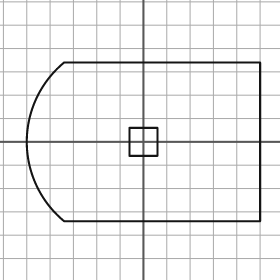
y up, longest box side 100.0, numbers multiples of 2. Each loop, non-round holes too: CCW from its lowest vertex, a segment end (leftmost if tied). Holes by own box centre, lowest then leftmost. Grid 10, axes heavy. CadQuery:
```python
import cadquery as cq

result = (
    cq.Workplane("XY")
    .moveTo(-34.0, -34.0)
    .lineTo(50.0, -34.0)
    .lineTo(50.0, 34.0)
    .lineTo(-34.0, 34.0)
    .threePointArc((-50.0, 0.0), (-34.0, -34.0))
    .close()
    .moveTo(-6.0, -6.0)
    .lineTo(6.0, -6.0)
    .lineTo(6.0, 6.0)
    .lineTo(-6.0, 6.0)
    .close()
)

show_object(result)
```